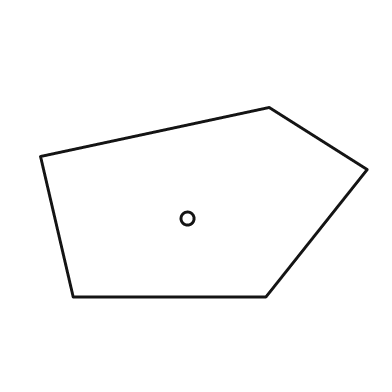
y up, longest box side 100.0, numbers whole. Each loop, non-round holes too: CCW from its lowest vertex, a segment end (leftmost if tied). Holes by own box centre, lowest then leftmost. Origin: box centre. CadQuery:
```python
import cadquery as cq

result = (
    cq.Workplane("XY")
    .moveTo(-40.0, -29.0)
    .lineTo(19.0, -29.0)
    .lineTo(50.0, 10.0)
    .lineTo(20.0, 29.0)
    .lineTo(-50.0, 14.0)
    .close()
    .moveTo(-5.0, -5.0)
    .circle(2.0)
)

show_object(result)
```